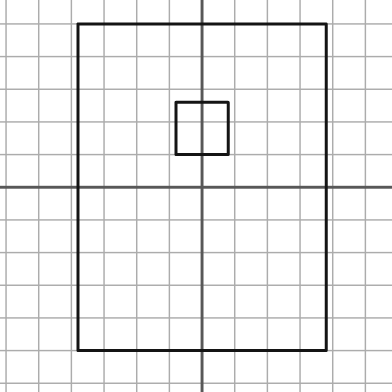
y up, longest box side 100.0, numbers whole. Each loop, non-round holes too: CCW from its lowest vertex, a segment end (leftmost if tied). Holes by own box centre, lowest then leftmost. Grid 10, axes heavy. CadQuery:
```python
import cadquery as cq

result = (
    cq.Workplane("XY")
    .moveTo(-38.0, -50.0)
    .lineTo(38.0, -50.0)
    .lineTo(38.0, 50.0)
    .lineTo(-38.0, 50.0)
    .close()
    .moveTo(-8.0, 10.0)
    .lineTo(8.0, 10.0)
    .lineTo(8.0, 26.0)
    .lineTo(-8.0, 26.0)
    .close()
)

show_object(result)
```